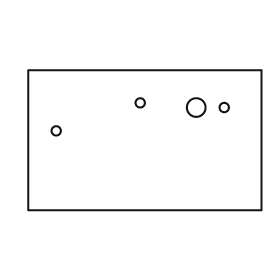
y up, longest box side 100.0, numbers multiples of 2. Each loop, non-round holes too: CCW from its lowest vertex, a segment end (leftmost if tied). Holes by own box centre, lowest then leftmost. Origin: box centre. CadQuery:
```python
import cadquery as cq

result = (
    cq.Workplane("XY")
    .moveTo(-50.0, -30.0)
    .lineTo(50.0, -30.0)
    .lineTo(50.0, 30.0)
    .lineTo(-50.0, 30.0)
    .close()
    .moveTo(-38.0, 4.0)
    .circle(2.0)
    .moveTo(22.0, 14.0)
    .circle(4.0)
    .moveTo(34.0, 14.0)
    .circle(2.0)
    .moveTo(-2.0, 16.0)
    .circle(2.0)
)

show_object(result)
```